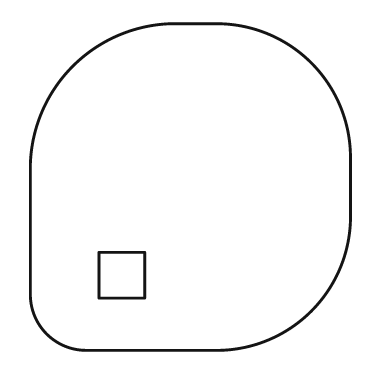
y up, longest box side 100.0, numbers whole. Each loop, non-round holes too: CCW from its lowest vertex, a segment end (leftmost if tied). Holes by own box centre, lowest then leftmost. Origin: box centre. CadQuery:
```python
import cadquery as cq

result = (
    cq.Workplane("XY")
    .moveTo(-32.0, -50.0)
    .lineTo(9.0, -50.0)
    .threePointArc((37.0, -38.0), (49.0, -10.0))
    .lineTo(49.0, 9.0)
    .threePointArc((37.0, 38.0), (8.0, 50.0))
    .lineTo(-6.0, 50.0)
    .threePointArc((-36.0, 37.0), (-49.0, 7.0))
    .lineTo(-49.0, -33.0)
    .threePointArc((-44.0, -45.0), (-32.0, -50.0))
    .close()
    .moveTo(-28.0, -34.0)
    .lineTo(-14.0, -34.0)
    .lineTo(-14.0, -20.0)
    .lineTo(-28.0, -20.0)
    .close()
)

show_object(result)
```